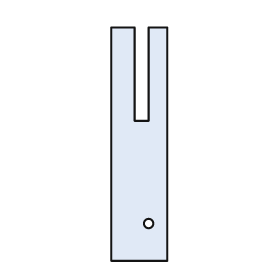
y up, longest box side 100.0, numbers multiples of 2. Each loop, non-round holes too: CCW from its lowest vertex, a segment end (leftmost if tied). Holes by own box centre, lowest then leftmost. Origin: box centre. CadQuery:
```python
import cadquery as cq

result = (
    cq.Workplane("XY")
    .moveTo(-12.0, -50.0)
    .lineTo(12.0, -50.0)
    .lineTo(12.0, 50.0)
    .lineTo(4.0, 50.0)
    .lineTo(4.0, 10.0)
    .lineTo(-2.0, 10.0)
    .lineTo(-2.0, 50.0)
    .lineTo(-12.0, 50.0)
    .close()
    .moveTo(4.0, -34.0)
    .circle(2.0)
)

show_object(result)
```